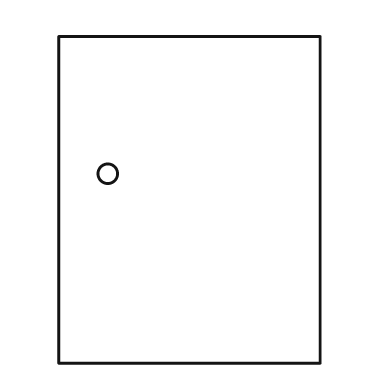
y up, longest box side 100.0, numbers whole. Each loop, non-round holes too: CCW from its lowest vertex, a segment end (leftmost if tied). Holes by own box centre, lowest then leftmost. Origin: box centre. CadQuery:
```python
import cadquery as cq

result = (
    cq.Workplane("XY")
    .moveTo(-40.0, -50.0)
    .lineTo(40.0, -50.0)
    .lineTo(40.0, 50.0)
    .lineTo(-40.0, 50.0)
    .close()
    .moveTo(-25.0, 8.0)
    .circle(3.0)
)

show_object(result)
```